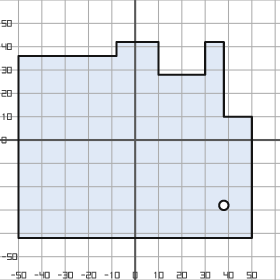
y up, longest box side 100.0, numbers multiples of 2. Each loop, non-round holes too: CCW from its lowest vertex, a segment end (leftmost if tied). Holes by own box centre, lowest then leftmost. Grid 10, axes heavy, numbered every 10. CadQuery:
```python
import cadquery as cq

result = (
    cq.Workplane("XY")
    .moveTo(-50.0, -42.0)
    .lineTo(50.0, -42.0)
    .lineTo(50.0, 10.0)
    .lineTo(38.0, 10.0)
    .lineTo(38.0, 42.0)
    .lineTo(30.0, 42.0)
    .lineTo(30.0, 28.0)
    .lineTo(10.0, 28.0)
    .lineTo(10.0, 42.0)
    .lineTo(-8.0, 42.0)
    .lineTo(-8.0, 36.0)
    .lineTo(-50.0, 36.0)
    .close()
    .moveTo(38.0, -28.0)
    .circle(2.0)
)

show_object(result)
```